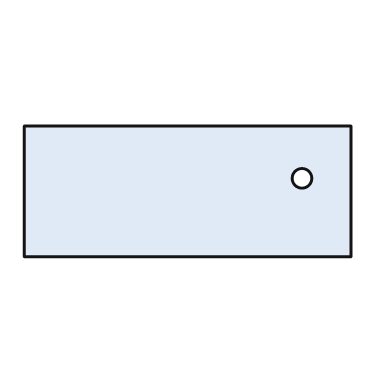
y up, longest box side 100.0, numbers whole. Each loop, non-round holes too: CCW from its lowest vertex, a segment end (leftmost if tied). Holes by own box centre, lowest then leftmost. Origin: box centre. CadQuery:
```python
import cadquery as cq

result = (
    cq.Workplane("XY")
    .moveTo(-50.0, -20.0)
    .lineTo(50.0, -20.0)
    .lineTo(50.0, 20.0)
    .lineTo(-50.0, 20.0)
    .close()
    .moveTo(35.0, 4.0)
    .circle(3.0)
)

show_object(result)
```